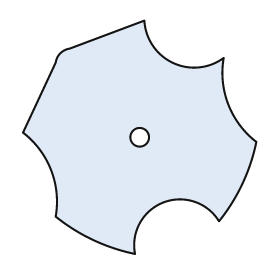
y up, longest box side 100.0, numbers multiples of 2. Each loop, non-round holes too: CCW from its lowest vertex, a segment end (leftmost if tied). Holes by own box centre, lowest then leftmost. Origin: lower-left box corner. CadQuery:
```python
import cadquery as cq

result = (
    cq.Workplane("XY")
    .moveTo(48.0, 0.0)
    .threePointArc((60.0, 22.0), (84.0, 14.0))
    .threePointArc((94.0, 30.0), (100.0, 48.0))
    .threePointArc((88.0, 64.0), (86.0, 84.0))
    .threePointArc((64.0, 82.0), (52.0, 100.0))
    .lineTo(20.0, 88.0)
    .threePointArc((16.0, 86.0), (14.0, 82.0))
    .lineTo(0.0, 52.0)
    .threePointArc((12.0, 36.0), (14.0, 16.0))
    .threePointArc((30.0, 6.0), (48.0, 0.0))
    .close()
    .moveTo(50.0, 50.0)
    .circle(4.0)
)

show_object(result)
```